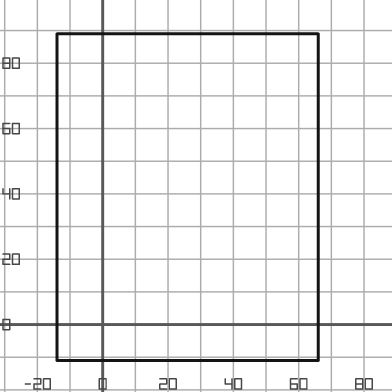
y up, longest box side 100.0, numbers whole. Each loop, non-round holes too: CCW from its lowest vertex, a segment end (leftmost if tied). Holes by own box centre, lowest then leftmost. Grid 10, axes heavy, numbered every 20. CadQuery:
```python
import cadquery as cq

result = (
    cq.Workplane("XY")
    .moveTo(-14.0, -11.0)
    .lineTo(66.0, -11.0)
    .lineTo(66.0, 89.0)
    .lineTo(-14.0, 89.0)
    .close()
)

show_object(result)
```